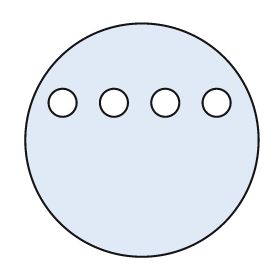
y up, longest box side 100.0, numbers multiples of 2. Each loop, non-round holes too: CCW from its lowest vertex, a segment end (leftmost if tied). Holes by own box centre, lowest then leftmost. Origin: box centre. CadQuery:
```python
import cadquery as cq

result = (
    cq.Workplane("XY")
    .moveTo(0.0, 0.0)
    .circle(50.0)
    .moveTo(-34.0, 16.0)
    .circle(6.0)
    .moveTo(-12.0, 16.0)
    .circle(6.0)
    .moveTo(10.0, 16.0)
    .circle(6.0)
    .moveTo(32.0, 16.0)
    .circle(6.0)
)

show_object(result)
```